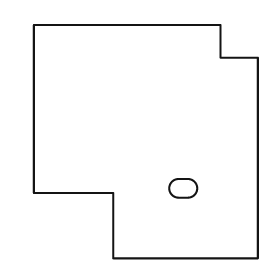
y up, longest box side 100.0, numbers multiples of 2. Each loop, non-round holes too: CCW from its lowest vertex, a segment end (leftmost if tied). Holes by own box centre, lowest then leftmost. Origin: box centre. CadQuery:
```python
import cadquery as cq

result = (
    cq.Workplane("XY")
    .moveTo(-14.0, -50.0)
    .lineTo(48.0, -50.0)
    .lineTo(48.0, 36.0)
    .lineTo(32.0, 36.0)
    .lineTo(32.0, 50.0)
    .lineTo(-48.0, 50.0)
    .lineTo(-48.0, -22.0)
    .lineTo(-14.0, -22.0)
    .close()
    .moveTo(14.0, -24.0)
    .lineTo(18.0, -24.0)
    .threePointArc((22.0, -20.0), (18.0, -16.0))
    .lineTo(14.0, -16.0)
    .threePointArc((10.0, -20.0), (14.0, -24.0))
    .close()
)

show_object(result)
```